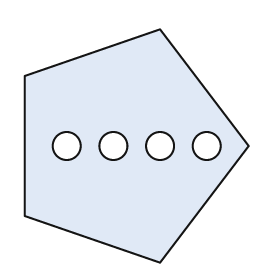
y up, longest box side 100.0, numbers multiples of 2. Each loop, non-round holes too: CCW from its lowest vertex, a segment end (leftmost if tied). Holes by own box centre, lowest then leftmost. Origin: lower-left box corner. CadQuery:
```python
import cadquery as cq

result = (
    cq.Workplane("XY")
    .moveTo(58.0, 0.0)
    .lineTo(96.0, 50.0)
    .lineTo(58.0, 100.0)
    .lineTo(0.0, 80.0)
    .lineTo(0.0, 20.0)
    .close()
    .moveTo(18.0, 50.0)
    .circle(6.0)
    .moveTo(38.0, 50.0)
    .circle(6.0)
    .moveTo(58.0, 50.0)
    .circle(6.0)
    .moveTo(78.0, 50.0)
    .circle(6.0)
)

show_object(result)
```